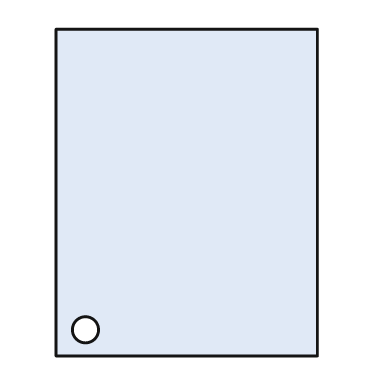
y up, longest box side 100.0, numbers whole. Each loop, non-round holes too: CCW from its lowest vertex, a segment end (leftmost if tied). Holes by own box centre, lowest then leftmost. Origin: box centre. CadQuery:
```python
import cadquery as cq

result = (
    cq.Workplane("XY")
    .moveTo(-40.0, -50.0)
    .lineTo(40.0, -50.0)
    .lineTo(40.0, 50.0)
    .lineTo(-40.0, 50.0)
    .close()
    .moveTo(-31.0, -42.0)
    .circle(4.0)
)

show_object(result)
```